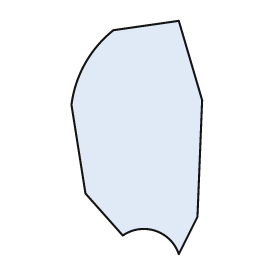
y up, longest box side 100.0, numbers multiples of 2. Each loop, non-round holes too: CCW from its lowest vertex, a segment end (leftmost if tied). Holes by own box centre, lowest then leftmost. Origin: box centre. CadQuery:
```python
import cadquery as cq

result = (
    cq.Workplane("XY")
    .moveTo(18.0, -50.0)
    .lineTo(26.0, -34.0)
    .lineTo(28.0, 16.0)
    .lineTo(18.0, 50.0)
    .lineTo(-10.0, 46.0)
    .threePointArc((-22.0, 32.0), (-28.0, 14.0))
    .lineTo(-22.0, -24.0)
    .lineTo(-6.0, -42.0)
    .threePointArc((8.0, -40.0), (18.0, -50.0))
    .close()
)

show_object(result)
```